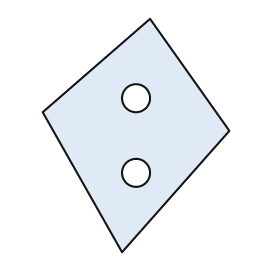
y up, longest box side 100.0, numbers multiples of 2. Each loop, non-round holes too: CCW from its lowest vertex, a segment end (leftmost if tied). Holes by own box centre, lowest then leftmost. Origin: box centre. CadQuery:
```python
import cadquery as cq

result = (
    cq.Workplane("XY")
    .moveTo(-6.0, -50.0)
    .lineTo(40.0, 2.0)
    .lineTo(6.0, 50.0)
    .lineTo(-40.0, 10.0)
    .close()
    .moveTo(0.0, -16.0)
    .circle(6.0)
    .moveTo(0.0, 16.0)
    .circle(6.0)
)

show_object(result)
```